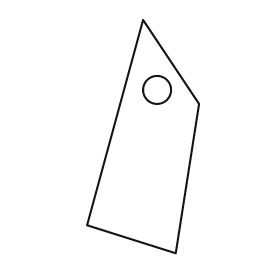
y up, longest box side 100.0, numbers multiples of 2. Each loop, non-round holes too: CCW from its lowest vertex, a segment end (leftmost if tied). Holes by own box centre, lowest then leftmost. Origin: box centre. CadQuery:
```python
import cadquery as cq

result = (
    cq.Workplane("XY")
    .moveTo(14.0, -50.0)
    .lineTo(24.0, 14.0)
    .lineTo(0.0, 50.0)
    .lineTo(-24.0, -38.0)
    .close()
    .moveTo(6.0, 20.0)
    .circle(6.0)
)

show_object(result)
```